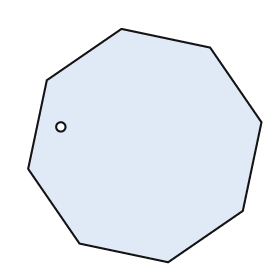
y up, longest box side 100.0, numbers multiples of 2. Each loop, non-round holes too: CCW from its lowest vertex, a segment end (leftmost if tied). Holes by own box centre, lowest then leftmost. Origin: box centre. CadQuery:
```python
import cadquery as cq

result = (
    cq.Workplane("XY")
    .moveTo(10.0, -50.0)
    .lineTo(42.0, -28.0)
    .lineTo(50.0, 10.0)
    .lineTo(28.0, 42.0)
    .lineTo(-10.0, 50.0)
    .lineTo(-42.0, 28.0)
    .lineTo(-50.0, -10.0)
    .lineTo(-28.0, -42.0)
    .close()
    .moveTo(-36.0, 8.0)
    .circle(2.0)
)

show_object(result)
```